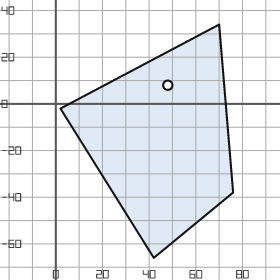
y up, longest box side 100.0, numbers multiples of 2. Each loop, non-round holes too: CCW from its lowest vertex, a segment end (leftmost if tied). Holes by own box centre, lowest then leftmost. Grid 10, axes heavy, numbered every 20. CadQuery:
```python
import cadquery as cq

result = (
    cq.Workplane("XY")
    .moveTo(42.0, -66.0)
    .lineTo(76.0, -38.0)
    .lineTo(70.0, 34.0)
    .lineTo(2.0, -2.0)
    .close()
    .moveTo(48.0, 8.0)
    .circle(2.0)
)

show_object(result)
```